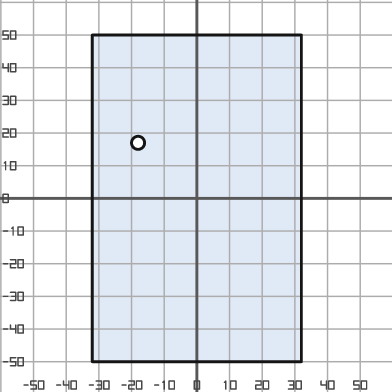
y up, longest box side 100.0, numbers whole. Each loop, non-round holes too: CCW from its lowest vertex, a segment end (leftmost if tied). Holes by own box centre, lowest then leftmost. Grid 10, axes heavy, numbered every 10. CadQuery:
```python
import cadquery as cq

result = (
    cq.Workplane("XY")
    .moveTo(-32.0, -50.0)
    .lineTo(32.0, -50.0)
    .lineTo(32.0, 50.0)
    .lineTo(-32.0, 50.0)
    .close()
    .moveTo(-18.0, 17.0)
    .circle(2.0)
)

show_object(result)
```